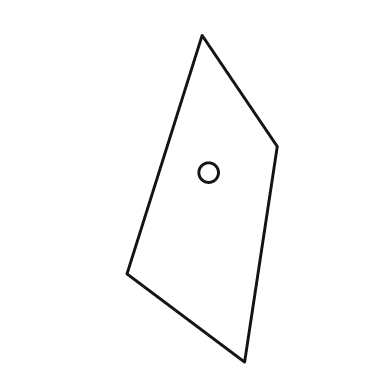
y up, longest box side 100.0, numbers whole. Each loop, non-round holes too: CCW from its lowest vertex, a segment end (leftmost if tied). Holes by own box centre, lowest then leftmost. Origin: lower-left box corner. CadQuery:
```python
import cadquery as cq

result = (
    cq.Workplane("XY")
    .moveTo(36.0, 0.0)
    .lineTo(46.0, 66.0)
    .lineTo(23.0, 100.0)
    .lineTo(0.0, 27.0)
    .close()
    .moveTo(25.0, 58.0)
    .circle(3.0)
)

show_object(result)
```